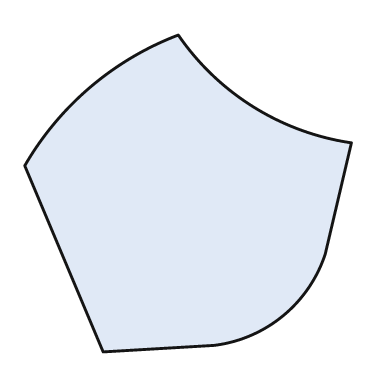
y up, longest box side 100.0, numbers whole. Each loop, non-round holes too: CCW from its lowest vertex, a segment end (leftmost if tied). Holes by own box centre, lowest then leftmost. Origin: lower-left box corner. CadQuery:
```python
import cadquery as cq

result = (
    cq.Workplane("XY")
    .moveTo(24.0, 0.0)
    .lineTo(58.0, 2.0)
    .threePointArc((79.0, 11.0), (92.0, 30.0))
    .lineTo(100.0, 64.0)
    .threePointArc((70.0, 75.0), (47.0, 97.0))
    .threePointArc((20.0, 81.0), (0.0, 57.0))
    .close()
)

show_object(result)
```